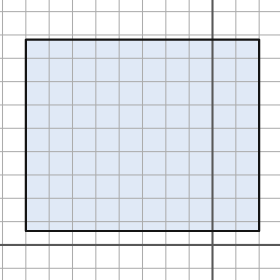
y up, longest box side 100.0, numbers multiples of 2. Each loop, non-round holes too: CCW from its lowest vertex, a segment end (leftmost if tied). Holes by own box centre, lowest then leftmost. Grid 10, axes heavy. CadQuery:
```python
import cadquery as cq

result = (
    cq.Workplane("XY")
    .moveTo(-80.0, 6.0)
    .lineTo(20.0, 6.0)
    .lineTo(20.0, 88.0)
    .lineTo(-80.0, 88.0)
    .close()
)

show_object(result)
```